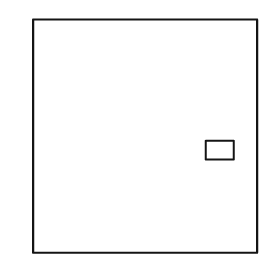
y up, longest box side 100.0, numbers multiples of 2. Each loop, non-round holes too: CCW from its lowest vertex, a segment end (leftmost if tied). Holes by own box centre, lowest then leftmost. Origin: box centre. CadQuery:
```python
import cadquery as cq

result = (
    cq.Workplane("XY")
    .moveTo(-48.0, -50.0)
    .lineTo(48.0, -50.0)
    .lineTo(48.0, 50.0)
    .lineTo(-48.0, 50.0)
    .close()
    .moveTo(26.0, -10.0)
    .lineTo(38.0, -10.0)
    .lineTo(38.0, -2.0)
    .lineTo(26.0, -2.0)
    .close()
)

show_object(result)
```